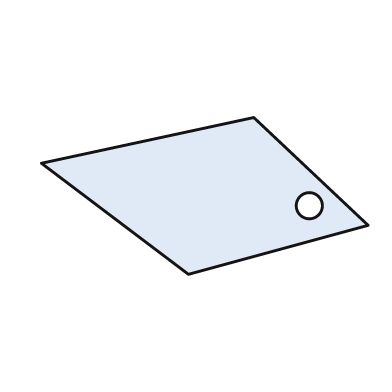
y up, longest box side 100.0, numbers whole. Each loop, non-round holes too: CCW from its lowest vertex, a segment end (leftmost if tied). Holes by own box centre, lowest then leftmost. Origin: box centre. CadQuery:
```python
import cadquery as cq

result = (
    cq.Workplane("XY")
    .moveTo(-5.0, -24.0)
    .lineTo(50.0, -9.0)
    .lineTo(15.0, 24.0)
    .lineTo(-50.0, 10.0)
    .close()
    .moveTo(32.0, -3.0)
    .circle(4.0)
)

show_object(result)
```